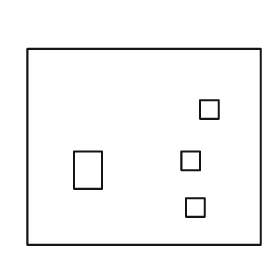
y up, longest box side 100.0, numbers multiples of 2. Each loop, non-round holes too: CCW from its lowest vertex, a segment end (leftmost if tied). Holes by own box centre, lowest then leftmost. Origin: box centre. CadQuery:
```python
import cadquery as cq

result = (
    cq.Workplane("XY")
    .moveTo(-50.0, -42.0)
    .lineTo(50.0, -42.0)
    .lineTo(50.0, 42.0)
    .lineTo(-50.0, 42.0)
    .close()
    .moveTo(18.0, -30.0)
    .lineTo(26.0, -30.0)
    .lineTo(26.0, -22.0)
    .lineTo(18.0, -22.0)
    .close()
    .moveTo(-30.0, -18.0)
    .lineTo(-18.0, -18.0)
    .lineTo(-18.0, -2.0)
    .lineTo(-30.0, -2.0)
    .close()
    .moveTo(16.0, -10.0)
    .lineTo(24.0, -10.0)
    .lineTo(24.0, -2.0)
    .lineTo(16.0, -2.0)
    .close()
    .moveTo(24.0, 12.0)
    .lineTo(32.0, 12.0)
    .lineTo(32.0, 20.0)
    .lineTo(24.0, 20.0)
    .close()
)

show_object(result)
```